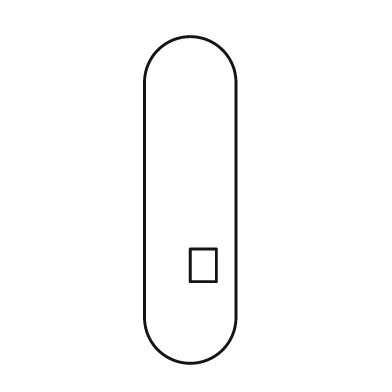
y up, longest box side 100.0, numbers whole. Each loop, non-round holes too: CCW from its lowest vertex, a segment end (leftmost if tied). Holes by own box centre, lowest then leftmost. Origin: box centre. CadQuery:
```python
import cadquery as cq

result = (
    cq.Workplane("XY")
    .moveTo(-14.0, -36.0)
    .threePointArc((0.0, -50.0), (14.0, -36.0))
    .lineTo(14.0, 36.0)
    .threePointArc((0.0, 50.0), (-14.0, 36.0))
    .close()
    .moveTo(0.0, -25.0)
    .lineTo(8.0, -25.0)
    .lineTo(8.0, -15.0)
    .lineTo(0.0, -15.0)
    .close()
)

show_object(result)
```